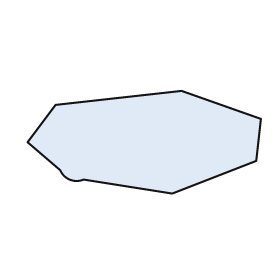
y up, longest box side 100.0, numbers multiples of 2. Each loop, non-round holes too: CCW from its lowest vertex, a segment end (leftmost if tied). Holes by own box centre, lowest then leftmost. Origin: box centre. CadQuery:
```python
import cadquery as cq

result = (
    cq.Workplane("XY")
    .moveTo(12.0, -22.0)
    .lineTo(48.0, -8.0)
    .lineTo(50.0, 10.0)
    .lineTo(16.0, 22.0)
    .lineTo(-38.0, 16.0)
    .lineTo(-50.0, 0.0)
    .lineTo(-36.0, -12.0)
    .threePointArc((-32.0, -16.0), (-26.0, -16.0))
    .close()
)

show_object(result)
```